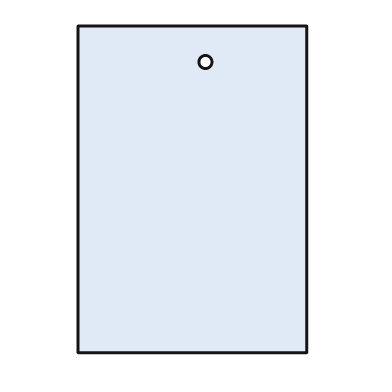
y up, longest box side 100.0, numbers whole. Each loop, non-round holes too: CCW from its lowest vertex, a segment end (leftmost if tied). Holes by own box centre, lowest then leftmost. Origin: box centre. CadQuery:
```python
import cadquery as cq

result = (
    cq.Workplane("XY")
    .moveTo(-35.0, -50.0)
    .lineTo(35.0, -50.0)
    .lineTo(35.0, 50.0)
    .lineTo(-35.0, 50.0)
    .close()
    .moveTo(4.0, 39.0)
    .circle(2.0)
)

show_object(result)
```